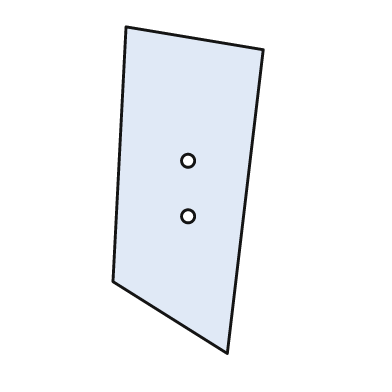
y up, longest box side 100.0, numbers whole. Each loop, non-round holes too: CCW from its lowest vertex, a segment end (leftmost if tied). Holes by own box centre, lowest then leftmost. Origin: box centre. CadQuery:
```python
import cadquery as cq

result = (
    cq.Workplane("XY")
    .moveTo(12.0, -50.0)
    .lineTo(23.0, 43.0)
    .lineTo(-19.0, 50.0)
    .lineTo(-23.0, -28.0)
    .close()
    .moveTo(0.0, -8.0)
    .circle(2.0)
    .moveTo(0.0, 9.0)
    .circle(2.0)
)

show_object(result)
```